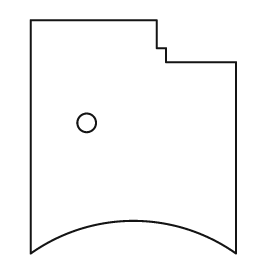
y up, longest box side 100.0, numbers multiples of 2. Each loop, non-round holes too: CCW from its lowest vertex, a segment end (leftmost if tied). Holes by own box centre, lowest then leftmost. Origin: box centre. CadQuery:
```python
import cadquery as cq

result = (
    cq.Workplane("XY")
    .moveTo(-44.0, -50.0)
    .threePointArc((0.0, -36.0), (44.0, -50.0))
    .lineTo(44.0, 32.0)
    .lineTo(14.0, 32.0)
    .lineTo(14.0, 38.0)
    .lineTo(10.0, 38.0)
    .lineTo(10.0, 50.0)
    .lineTo(-44.0, 50.0)
    .close()
    .moveTo(-20.0, 6.0)
    .circle(4.0)
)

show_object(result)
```